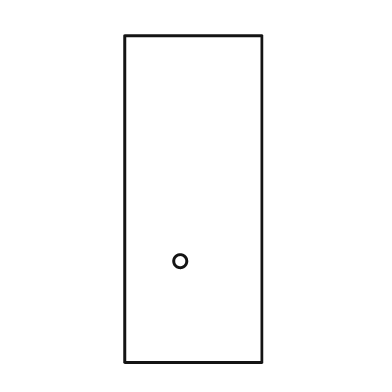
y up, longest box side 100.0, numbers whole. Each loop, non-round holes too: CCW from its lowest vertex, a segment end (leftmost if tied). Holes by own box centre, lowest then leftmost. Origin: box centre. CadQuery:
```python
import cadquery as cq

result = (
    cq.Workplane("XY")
    .moveTo(-21.0, -50.0)
    .lineTo(21.0, -50.0)
    .lineTo(21.0, 50.0)
    .lineTo(-21.0, 50.0)
    .close()
    .moveTo(-4.0, -19.0)
    .circle(2.0)
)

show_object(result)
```